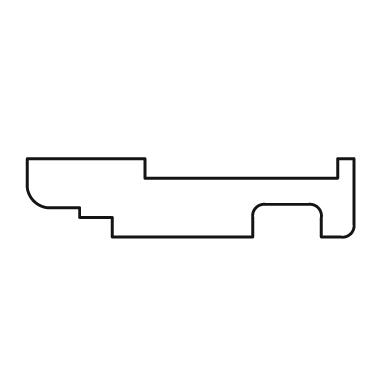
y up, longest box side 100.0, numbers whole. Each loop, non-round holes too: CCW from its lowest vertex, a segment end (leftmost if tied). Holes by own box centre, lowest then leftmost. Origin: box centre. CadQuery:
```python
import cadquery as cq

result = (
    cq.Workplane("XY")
    .moveTo(-24.0, -12.0)
    .lineTo(19.0, -12.0)
    .lineTo(19.0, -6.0)
    .threePointArc((20.0, -3.0), (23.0, -2.0))
    .lineTo(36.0, -2.0)
    .threePointArc((39.0, -3.0), (40.0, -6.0))
    .lineTo(40.0, -12.0)
    .lineTo(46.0, -12.0)
    .threePointArc((49.0, -11.0), (50.0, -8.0))
    .lineTo(50.0, 12.0)
    .lineTo(45.0, 12.0)
    .lineTo(45.0, 6.0)
    .lineTo(-14.0, 6.0)
    .lineTo(-14.0, 12.0)
    .lineTo(-50.0, 12.0)
    .lineTo(-50.0, 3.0)
    .threePointArc((-48.0, -1.0), (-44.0, -3.0))
    .lineTo(-34.0, -3.0)
    .lineTo(-34.0, -6.0)
    .lineTo(-24.0, -6.0)
    .close()
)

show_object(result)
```